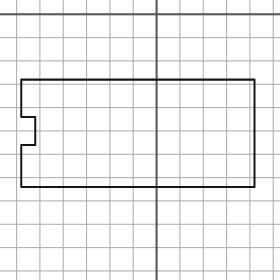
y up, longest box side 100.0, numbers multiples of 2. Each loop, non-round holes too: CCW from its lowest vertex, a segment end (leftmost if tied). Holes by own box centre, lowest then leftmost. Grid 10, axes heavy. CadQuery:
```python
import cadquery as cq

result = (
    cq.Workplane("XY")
    .moveTo(-58.0, -74.0)
    .lineTo(42.0, -74.0)
    .lineTo(42.0, -28.0)
    .lineTo(-58.0, -28.0)
    .lineTo(-58.0, -44.0)
    .lineTo(-52.0, -44.0)
    .lineTo(-52.0, -56.0)
    .lineTo(-58.0, -56.0)
    .close()
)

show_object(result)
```